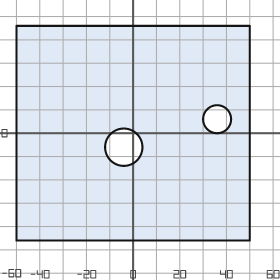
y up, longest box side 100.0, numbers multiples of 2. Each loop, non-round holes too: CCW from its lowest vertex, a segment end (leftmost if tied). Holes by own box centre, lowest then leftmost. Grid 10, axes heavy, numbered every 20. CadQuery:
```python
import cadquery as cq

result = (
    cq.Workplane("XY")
    .moveTo(-50.0, -46.0)
    .lineTo(50.0, -46.0)
    .lineTo(50.0, 46.0)
    .lineTo(-50.0, 46.0)
    .close()
    .moveTo(-4.0, -6.0)
    .circle(8.0)
    .moveTo(36.0, 6.0)
    .circle(6.0)
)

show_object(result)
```